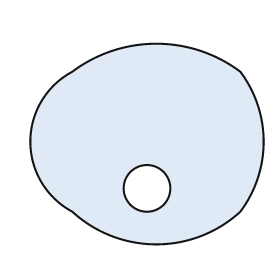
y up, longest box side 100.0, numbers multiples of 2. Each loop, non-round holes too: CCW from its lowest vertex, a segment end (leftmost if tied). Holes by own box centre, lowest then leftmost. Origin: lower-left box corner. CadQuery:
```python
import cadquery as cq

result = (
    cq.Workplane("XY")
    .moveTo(18.0, 14.0)
    .threePointArc((54.0, 0.0), (90.0, 14.0))
    .threePointArc((100.0, 44.0), (90.0, 74.0))
    .threePointArc((54.0, 86.0), (18.0, 74.0))
    .threePointArc((0.0, 44.0), (18.0, 14.0))
    .close()
    .moveTo(50.0, 24.0)
    .circle(10.0)
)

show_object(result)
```